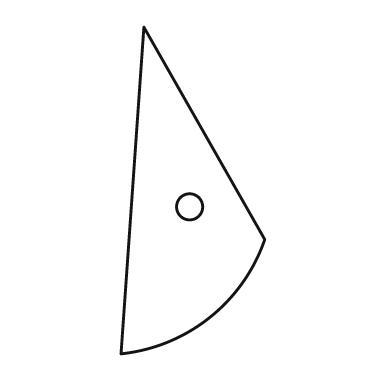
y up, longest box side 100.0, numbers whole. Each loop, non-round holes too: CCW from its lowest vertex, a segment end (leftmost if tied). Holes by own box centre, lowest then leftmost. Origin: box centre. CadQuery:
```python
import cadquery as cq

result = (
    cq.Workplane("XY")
    .moveTo(-22.0, -50.0)
    .threePointArc((5.0, -39.0), (22.0, -15.0))
    .lineTo(-15.0, 50.0)
    .close()
    .moveTo(-1.0, -5.0)
    .circle(4.0)
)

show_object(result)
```